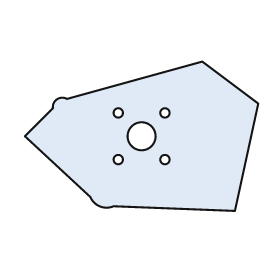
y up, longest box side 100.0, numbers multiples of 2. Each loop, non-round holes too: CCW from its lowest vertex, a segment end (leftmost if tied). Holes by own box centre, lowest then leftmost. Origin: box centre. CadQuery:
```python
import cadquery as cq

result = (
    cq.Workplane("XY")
    .moveTo(40.0, -32.0)
    .lineTo(50.0, 14.0)
    .lineTo(26.0, 32.0)
    .lineTo(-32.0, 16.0)
    .threePointArc((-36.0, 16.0), (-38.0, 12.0))
    .lineTo(-50.0, 0.0)
    .lineTo(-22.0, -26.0)
    .threePointArc((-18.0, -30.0), (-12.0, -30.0))
    .close()
    .moveTo(-10.0, -10.0)
    .circle(2.0)
    .moveTo(10.0, -10.0)
    .circle(2.0)
    .moveTo(0.0, 0.0)
    .circle(6.0)
    .moveTo(-10.0, 10.0)
    .circle(2.0)
    .moveTo(10.0, 10.0)
    .circle(2.0)
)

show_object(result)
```